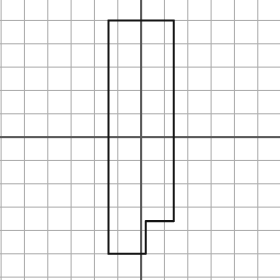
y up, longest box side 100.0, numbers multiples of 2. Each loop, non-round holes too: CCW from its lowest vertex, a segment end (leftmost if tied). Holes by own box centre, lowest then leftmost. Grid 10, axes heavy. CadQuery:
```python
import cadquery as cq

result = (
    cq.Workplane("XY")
    .moveTo(-14.0, -50.0)
    .lineTo(2.0, -50.0)
    .lineTo(2.0, -36.0)
    .lineTo(14.0, -36.0)
    .lineTo(14.0, 50.0)
    .lineTo(-14.0, 50.0)
    .close()
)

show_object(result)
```